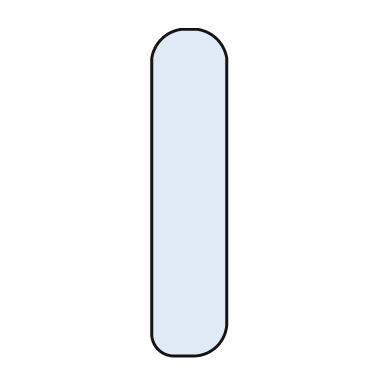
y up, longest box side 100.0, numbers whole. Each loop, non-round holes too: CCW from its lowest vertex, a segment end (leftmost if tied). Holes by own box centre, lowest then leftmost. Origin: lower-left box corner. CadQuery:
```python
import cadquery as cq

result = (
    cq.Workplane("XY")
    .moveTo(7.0, 0.0)
    .lineTo(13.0, 0.0)
    .threePointArc((20.0, 3.0), (23.0, 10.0))
    .lineTo(23.0, 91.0)
    .threePointArc((20.0, 97.0), (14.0, 100.0))
    .lineTo(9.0, 100.0)
    .threePointArc((3.0, 97.0), (0.0, 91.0))
    .lineTo(0.0, 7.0)
    .threePointArc((2.0, 2.0), (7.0, 0.0))
    .close()
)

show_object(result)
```